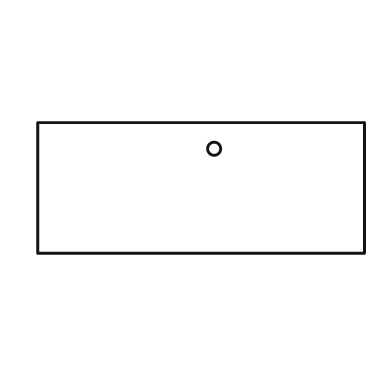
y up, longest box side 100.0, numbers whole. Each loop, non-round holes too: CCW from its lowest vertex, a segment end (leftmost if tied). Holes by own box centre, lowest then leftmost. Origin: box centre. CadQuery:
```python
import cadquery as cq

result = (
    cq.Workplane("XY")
    .moveTo(-50.0, -20.0)
    .lineTo(50.0, -20.0)
    .lineTo(50.0, 20.0)
    .lineTo(-50.0, 20.0)
    .close()
    .moveTo(4.0, 12.0)
    .circle(2.0)
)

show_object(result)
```